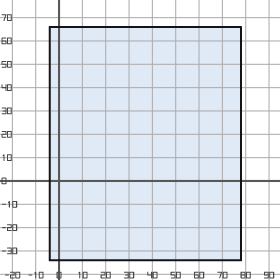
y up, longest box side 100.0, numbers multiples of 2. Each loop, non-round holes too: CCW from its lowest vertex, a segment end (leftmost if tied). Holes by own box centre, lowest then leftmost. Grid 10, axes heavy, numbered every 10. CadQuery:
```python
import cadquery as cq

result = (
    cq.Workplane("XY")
    .moveTo(-4.0, -34.0)
    .lineTo(78.0, -34.0)
    .lineTo(78.0, 66.0)
    .lineTo(-4.0, 66.0)
    .close()
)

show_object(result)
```